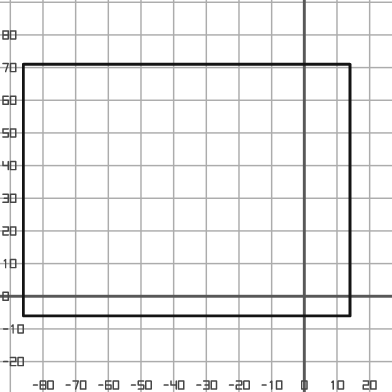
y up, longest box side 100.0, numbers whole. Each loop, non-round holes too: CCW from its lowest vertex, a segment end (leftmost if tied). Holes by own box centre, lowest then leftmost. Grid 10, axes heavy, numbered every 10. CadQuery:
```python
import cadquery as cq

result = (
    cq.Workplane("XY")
    .moveTo(-86.0, -6.0)
    .lineTo(14.0, -6.0)
    .lineTo(14.0, 71.0)
    .lineTo(-86.0, 71.0)
    .close()
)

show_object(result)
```